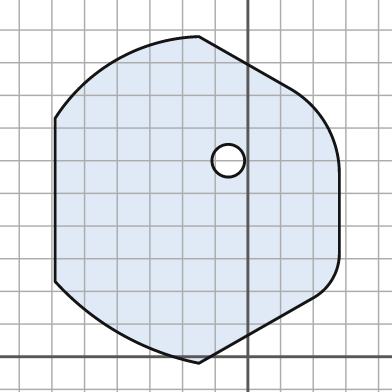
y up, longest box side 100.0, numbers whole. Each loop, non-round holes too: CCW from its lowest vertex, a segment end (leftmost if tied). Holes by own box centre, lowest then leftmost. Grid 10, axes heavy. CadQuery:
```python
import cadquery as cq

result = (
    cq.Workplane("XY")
    .moveTo(-15.0, -2.0)
    .lineTo(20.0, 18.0)
    .threePointArc((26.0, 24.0), (28.0, 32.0))
    .lineTo(28.0, 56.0)
    .threePointArc((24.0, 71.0), (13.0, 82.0))
    .lineTo(-15.0, 98.0)
    .threePointArc((-40.0, 91.0), (-59.0, 73.0))
    .lineTo(-59.0, 23.0)
    .threePointArc((-39.0, 7.0), (-15.0, -2.0))
    .close()
    .moveTo(-6.0, 60.0)
    .circle(5.0)
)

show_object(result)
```